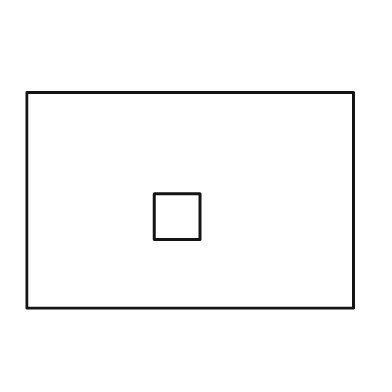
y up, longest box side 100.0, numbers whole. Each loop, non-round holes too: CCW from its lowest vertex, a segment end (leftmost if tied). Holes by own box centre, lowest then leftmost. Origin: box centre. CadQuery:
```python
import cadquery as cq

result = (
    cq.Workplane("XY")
    .moveTo(-50.0, -33.0)
    .lineTo(50.0, -33.0)
    .lineTo(50.0, 33.0)
    .lineTo(-50.0, 33.0)
    .close()
    .moveTo(-11.0, -12.0)
    .lineTo(3.0, -12.0)
    .lineTo(3.0, 2.0)
    .lineTo(-11.0, 2.0)
    .close()
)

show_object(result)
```